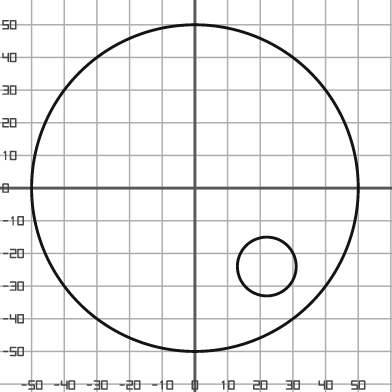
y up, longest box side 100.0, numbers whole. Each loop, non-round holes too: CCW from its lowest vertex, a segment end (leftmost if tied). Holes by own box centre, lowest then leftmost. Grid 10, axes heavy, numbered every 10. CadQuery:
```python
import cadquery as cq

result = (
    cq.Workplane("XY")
    .moveTo(0.0, 0.0)
    .circle(50.0)
    .moveTo(22.0, -24.0)
    .circle(9.0)
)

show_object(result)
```